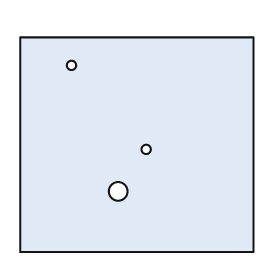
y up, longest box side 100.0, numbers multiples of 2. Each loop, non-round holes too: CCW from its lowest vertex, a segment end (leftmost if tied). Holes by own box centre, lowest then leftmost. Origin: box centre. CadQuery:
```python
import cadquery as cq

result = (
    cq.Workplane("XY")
    .moveTo(-50.0, -46.0)
    .lineTo(50.0, -46.0)
    .lineTo(50.0, 46.0)
    .lineTo(-50.0, 46.0)
    .close()
    .moveTo(-8.0, -20.0)
    .circle(4.0)
    .moveTo(4.0, -2.0)
    .circle(2.0)
    .moveTo(-28.0, 34.0)
    .circle(2.0)
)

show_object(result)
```